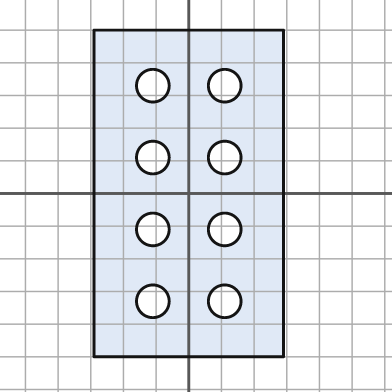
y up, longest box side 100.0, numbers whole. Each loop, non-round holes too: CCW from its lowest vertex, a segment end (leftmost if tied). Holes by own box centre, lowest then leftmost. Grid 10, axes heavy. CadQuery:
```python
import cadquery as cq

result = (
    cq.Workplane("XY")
    .moveTo(-29.0, -50.0)
    .lineTo(29.0, -50.0)
    .lineTo(29.0, 50.0)
    .lineTo(-29.0, 50.0)
    .close()
    .moveTo(-11.0, -33.0)
    .circle(5.0)
    .moveTo(11.0, -33.0)
    .circle(5.0)
    .moveTo(-11.0, -11.0)
    .circle(5.0)
    .moveTo(11.0, -11.0)
    .circle(5.0)
    .moveTo(-11.0, 11.0)
    .circle(5.0)
    .moveTo(11.0, 11.0)
    .circle(5.0)
    .moveTo(-11.0, 33.0)
    .circle(5.0)
    .moveTo(11.0, 33.0)
    .circle(5.0)
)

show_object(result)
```